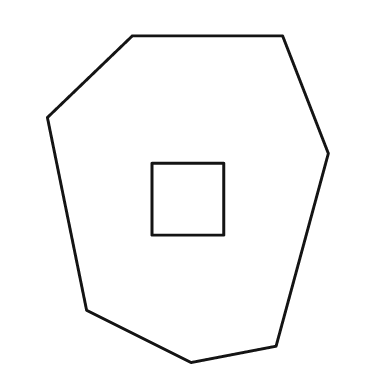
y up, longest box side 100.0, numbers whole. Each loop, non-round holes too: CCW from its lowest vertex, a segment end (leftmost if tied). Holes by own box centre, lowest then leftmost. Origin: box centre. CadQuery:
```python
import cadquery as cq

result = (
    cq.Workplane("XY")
    .moveTo(1.0, -50.0)
    .lineTo(27.0, -45.0)
    .lineTo(43.0, 14.0)
    .lineTo(29.0, 50.0)
    .lineTo(-17.0, 50.0)
    .lineTo(-43.0, 25.0)
    .lineTo(-31.0, -34.0)
    .close()
    .moveTo(-11.0, -11.0)
    .lineTo(11.0, -11.0)
    .lineTo(11.0, 11.0)
    .lineTo(-11.0, 11.0)
    .close()
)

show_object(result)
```